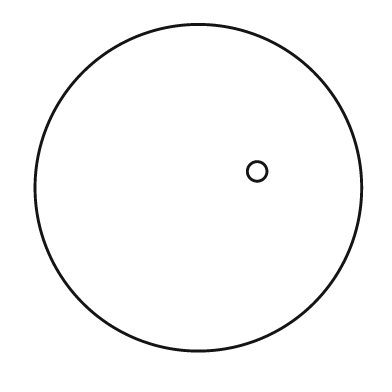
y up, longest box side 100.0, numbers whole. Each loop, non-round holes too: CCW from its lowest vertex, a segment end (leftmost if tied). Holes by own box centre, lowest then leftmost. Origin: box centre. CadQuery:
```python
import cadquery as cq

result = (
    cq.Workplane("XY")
    .moveTo(0.0, 0.0)
    .circle(50.0)
    .moveTo(18.0, 5.0)
    .circle(3.0)
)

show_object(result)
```